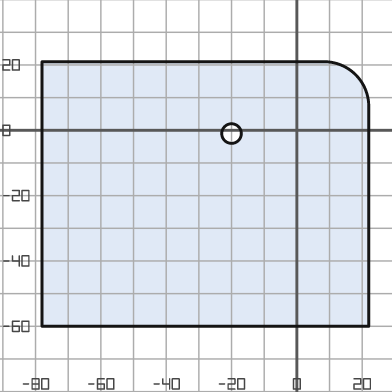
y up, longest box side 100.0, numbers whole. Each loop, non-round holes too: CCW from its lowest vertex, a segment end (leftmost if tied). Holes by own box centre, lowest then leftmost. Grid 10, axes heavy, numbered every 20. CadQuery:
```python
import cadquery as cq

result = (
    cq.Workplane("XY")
    .moveTo(-78.0, -60.0)
    .lineTo(22.0, -60.0)
    .lineTo(22.0, 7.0)
    .threePointArc((18.0, 17.0), (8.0, 21.0))
    .lineTo(-78.0, 21.0)
    .close()
    .moveTo(-20.0, -1.0)
    .circle(3.0)
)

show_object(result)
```